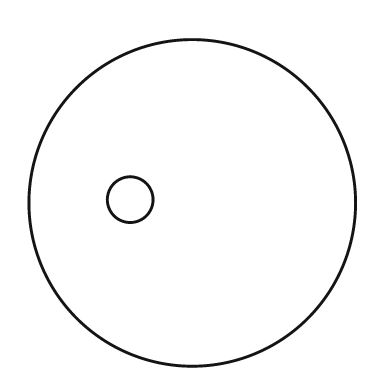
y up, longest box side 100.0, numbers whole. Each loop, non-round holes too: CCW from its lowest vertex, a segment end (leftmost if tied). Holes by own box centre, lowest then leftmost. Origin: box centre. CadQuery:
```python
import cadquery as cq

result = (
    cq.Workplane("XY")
    .moveTo(0.0, 0.0)
    .circle(50.0)
    .moveTo(-19.0, 1.0)
    .circle(7.0)
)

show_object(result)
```